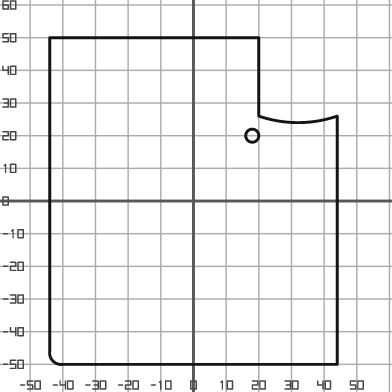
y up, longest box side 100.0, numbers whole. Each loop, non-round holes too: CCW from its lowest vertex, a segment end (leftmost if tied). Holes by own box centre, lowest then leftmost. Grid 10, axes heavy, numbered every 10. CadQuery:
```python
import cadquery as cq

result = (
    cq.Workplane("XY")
    .moveTo(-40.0, -50.0)
    .lineTo(44.0, -50.0)
    .lineTo(44.0, 26.0)
    .threePointArc((32.0, 24.0), (20.0, 26.0))
    .lineTo(20.0, 50.0)
    .lineTo(-44.0, 50.0)
    .lineTo(-44.0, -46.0)
    .threePointArc((-43.0, -49.0), (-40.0, -50.0))
    .close()
    .moveTo(18.0, 20.0)
    .circle(2.0)
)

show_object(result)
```